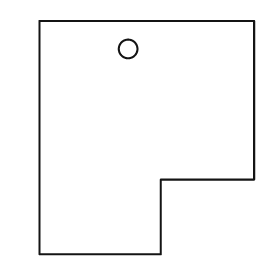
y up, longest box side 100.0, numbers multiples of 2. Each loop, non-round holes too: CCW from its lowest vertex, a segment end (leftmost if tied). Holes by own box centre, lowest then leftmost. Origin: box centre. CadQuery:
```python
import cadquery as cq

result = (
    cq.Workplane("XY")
    .moveTo(-46.0, -50.0)
    .lineTo(6.0, -50.0)
    .lineTo(6.0, -18.0)
    .lineTo(46.0, -18.0)
    .lineTo(46.0, 50.0)
    .lineTo(-46.0, 50.0)
    .close()
    .moveTo(-8.0, 38.0)
    .circle(4.0)
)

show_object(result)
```